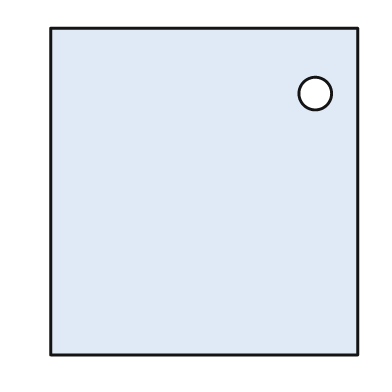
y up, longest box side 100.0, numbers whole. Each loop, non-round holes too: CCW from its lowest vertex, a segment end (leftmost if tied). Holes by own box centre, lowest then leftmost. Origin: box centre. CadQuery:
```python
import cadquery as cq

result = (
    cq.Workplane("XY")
    .moveTo(-47.0, -50.0)
    .lineTo(47.0, -50.0)
    .lineTo(47.0, 50.0)
    .lineTo(-47.0, 50.0)
    .close()
    .moveTo(34.0, 30.0)
    .circle(5.0)
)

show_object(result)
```